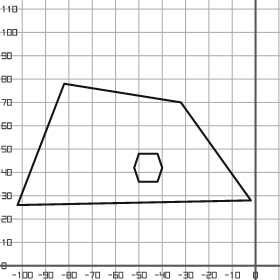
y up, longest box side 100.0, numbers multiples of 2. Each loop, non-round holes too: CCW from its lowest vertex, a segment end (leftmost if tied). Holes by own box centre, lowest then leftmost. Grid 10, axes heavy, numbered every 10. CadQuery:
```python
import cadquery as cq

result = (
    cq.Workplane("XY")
    .moveTo(-102.0, 26.0)
    .lineTo(-2.0, 28.0)
    .lineTo(-32.0, 70.0)
    .lineTo(-82.0, 78.0)
    .close()
    .moveTo(-50.0, 36.0)
    .lineTo(-42.0, 36.0)
    .lineTo(-40.0, 42.0)
    .lineTo(-42.0, 48.0)
    .lineTo(-50.0, 48.0)
    .lineTo(-52.0, 42.0)
    .close()
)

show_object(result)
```